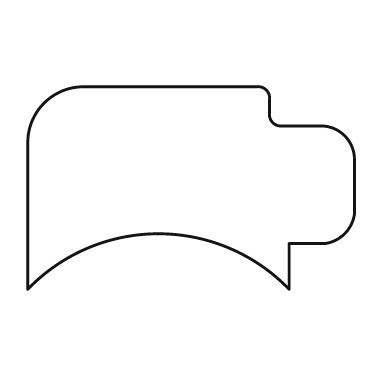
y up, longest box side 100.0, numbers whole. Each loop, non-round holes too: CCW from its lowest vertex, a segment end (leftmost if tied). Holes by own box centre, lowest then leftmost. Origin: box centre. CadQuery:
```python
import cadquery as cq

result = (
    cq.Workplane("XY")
    .moveTo(-50.0, -31.0)
    .threePointArc((-10.0, -14.0), (30.0, -31.0))
    .lineTo(30.0, -17.0)
    .lineTo(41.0, -17.0)
    .threePointArc((47.0, -14.0), (50.0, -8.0))
    .lineTo(50.0, 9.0)
    .threePointArc((47.0, 16.0), (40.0, 19.0))
    .lineTo(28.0, 19.0)
    .threePointArc((25.0, 20.0), (24.0, 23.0))
    .lineTo(24.0, 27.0)
    .threePointArc((23.0, 30.0), (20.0, 31.0))
    .lineTo(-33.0, 31.0)
    .threePointArc((-45.0, 26.0), (-50.0, 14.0))
    .close()
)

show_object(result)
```